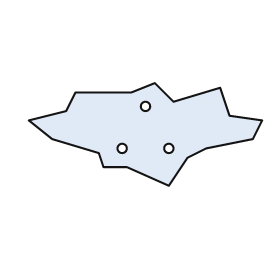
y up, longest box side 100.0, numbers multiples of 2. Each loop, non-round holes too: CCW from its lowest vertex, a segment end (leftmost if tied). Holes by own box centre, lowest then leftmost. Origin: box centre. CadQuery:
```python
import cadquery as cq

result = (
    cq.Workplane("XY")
    .moveTo(10.0, -22.0)
    .lineTo(18.0, -10.0)
    .lineTo(26.0, -6.0)
    .lineTo(46.0, -2.0)
    .lineTo(50.0, 6.0)
    .lineTo(36.0, 8.0)
    .lineTo(32.0, 20.0)
    .lineTo(12.0, 14.0)
    .lineTo(4.0, 22.0)
    .lineTo(-6.0, 18.0)
    .lineTo(-30.0, 18.0)
    .lineTo(-34.0, 10.0)
    .lineTo(-50.0, 6.0)
    .lineTo(-40.0, -2.0)
    .lineTo(-20.0, -8.0)
    .lineTo(-18.0, -14.0)
    .lineTo(-8.0, -14.0)
    .close()
    .moveTo(-10.0, -6.0)
    .circle(2.0)
    .moveTo(10.0, -6.0)
    .circle(2.0)
    .moveTo(0.0, 12.0)
    .circle(2.0)
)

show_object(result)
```